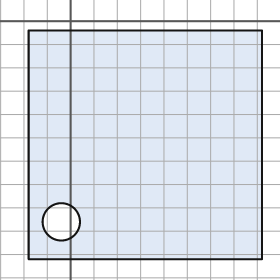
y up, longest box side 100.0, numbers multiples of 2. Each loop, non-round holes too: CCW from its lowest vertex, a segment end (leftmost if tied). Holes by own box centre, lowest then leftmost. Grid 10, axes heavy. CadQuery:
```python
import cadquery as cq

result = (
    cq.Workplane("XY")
    .moveTo(-18.0, -102.0)
    .lineTo(82.0, -102.0)
    .lineTo(82.0, -4.0)
    .lineTo(-18.0, -4.0)
    .close()
    .moveTo(-4.0, -86.0)
    .circle(8.0)
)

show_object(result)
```